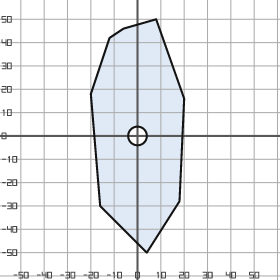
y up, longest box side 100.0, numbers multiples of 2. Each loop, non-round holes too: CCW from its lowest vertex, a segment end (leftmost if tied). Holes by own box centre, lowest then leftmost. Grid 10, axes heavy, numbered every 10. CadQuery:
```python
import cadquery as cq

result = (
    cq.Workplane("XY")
    .moveTo(4.0, -50.0)
    .lineTo(18.0, -28.0)
    .lineTo(20.0, 16.0)
    .lineTo(8.0, 50.0)
    .lineTo(-6.0, 46.0)
    .lineTo(-12.0, 42.0)
    .lineTo(-20.0, 18.0)
    .lineTo(-16.0, -30.0)
    .close()
    .moveTo(0.0, 0.0)
    .circle(4.0)
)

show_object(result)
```